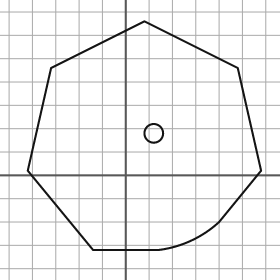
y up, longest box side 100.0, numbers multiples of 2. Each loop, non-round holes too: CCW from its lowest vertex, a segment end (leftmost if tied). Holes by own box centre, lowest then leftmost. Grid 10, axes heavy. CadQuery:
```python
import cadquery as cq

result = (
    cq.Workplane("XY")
    .moveTo(-14.0, -32.0)
    .lineTo(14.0, -32.0)
    .threePointArc((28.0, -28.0), (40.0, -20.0))
    .lineTo(58.0, 2.0)
    .lineTo(48.0, 46.0)
    .lineTo(8.0, 66.0)
    .lineTo(-32.0, 46.0)
    .lineTo(-42.0, 2.0)
    .close()
    .moveTo(12.0, 18.0)
    .circle(4.0)
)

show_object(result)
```